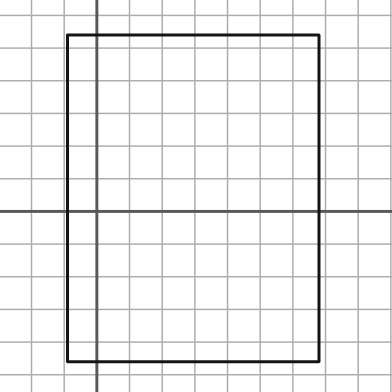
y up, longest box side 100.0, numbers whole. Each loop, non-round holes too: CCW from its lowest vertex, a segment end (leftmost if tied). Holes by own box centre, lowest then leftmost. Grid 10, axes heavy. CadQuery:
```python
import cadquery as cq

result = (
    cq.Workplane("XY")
    .moveTo(-9.0, -46.0)
    .lineTo(68.0, -46.0)
    .lineTo(68.0, 54.0)
    .lineTo(-9.0, 54.0)
    .close()
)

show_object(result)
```